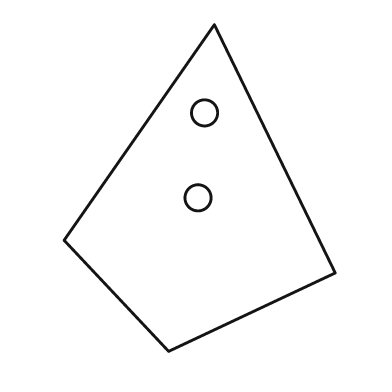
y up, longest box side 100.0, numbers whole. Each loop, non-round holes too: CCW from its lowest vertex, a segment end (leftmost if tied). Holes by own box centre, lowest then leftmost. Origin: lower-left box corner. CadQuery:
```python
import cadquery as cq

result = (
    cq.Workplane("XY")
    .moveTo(32.0, 0.0)
    .lineTo(83.0, 24.0)
    .lineTo(46.0, 100.0)
    .lineTo(0.0, 34.0)
    .close()
    .moveTo(41.0, 47.0)
    .circle(4.0)
    .moveTo(43.0, 73.0)
    .circle(4.0)
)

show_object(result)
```